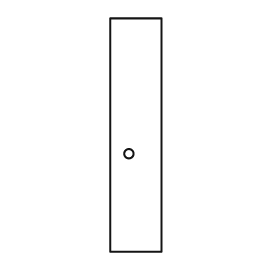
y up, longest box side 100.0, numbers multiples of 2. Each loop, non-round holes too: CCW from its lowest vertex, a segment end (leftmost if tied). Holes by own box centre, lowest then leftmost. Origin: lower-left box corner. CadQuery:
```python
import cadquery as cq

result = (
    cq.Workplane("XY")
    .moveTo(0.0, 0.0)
    .lineTo(22.0, 0.0)
    .lineTo(22.0, 100.0)
    .lineTo(0.0, 100.0)
    .close()
    .moveTo(8.0, 42.0)
    .circle(2.0)
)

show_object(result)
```